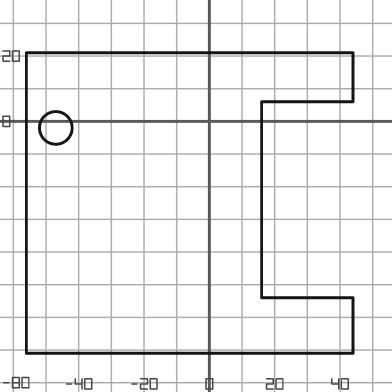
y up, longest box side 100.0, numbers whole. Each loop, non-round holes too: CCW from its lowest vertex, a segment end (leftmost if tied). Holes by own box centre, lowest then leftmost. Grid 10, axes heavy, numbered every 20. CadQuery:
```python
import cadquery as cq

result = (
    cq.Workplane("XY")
    .moveTo(-56.0, -71.0)
    .lineTo(44.0, -71.0)
    .lineTo(44.0, -54.0)
    .lineTo(16.0, -54.0)
    .lineTo(16.0, 6.0)
    .lineTo(44.0, 6.0)
    .lineTo(44.0, 21.0)
    .lineTo(-56.0, 21.0)
    .close()
    .moveTo(-47.0, -2.0)
    .circle(5.0)
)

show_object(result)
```